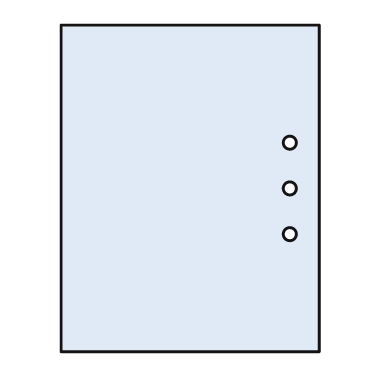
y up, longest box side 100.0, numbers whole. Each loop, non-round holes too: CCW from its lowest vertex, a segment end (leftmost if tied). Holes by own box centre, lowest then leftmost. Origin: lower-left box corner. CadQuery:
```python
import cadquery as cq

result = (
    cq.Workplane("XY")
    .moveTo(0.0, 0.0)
    .lineTo(79.0, 0.0)
    .lineTo(79.0, 100.0)
    .lineTo(0.0, 100.0)
    .close()
    .moveTo(70.0, 36.0)
    .circle(2.0)
    .moveTo(70.0, 50.0)
    .circle(2.0)
    .moveTo(70.0, 64.0)
    .circle(2.0)
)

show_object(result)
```